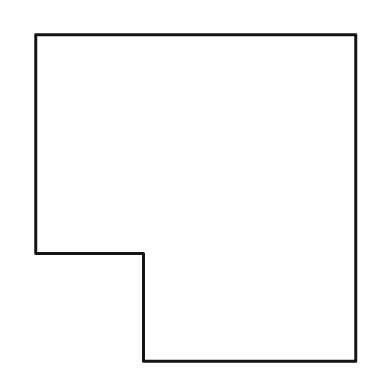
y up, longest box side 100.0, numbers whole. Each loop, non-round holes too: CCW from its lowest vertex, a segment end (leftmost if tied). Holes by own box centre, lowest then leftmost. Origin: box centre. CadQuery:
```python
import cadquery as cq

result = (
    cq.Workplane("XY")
    .moveTo(-16.0, -50.0)
    .lineTo(49.0, -50.0)
    .lineTo(49.0, 50.0)
    .lineTo(-49.0, 50.0)
    .lineTo(-49.0, -17.0)
    .lineTo(-16.0, -17.0)
    .close()
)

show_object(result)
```